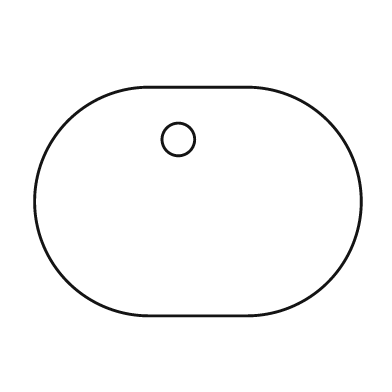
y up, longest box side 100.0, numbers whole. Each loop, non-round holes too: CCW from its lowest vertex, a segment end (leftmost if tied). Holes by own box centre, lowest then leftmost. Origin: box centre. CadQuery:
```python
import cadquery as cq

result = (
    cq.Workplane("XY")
    .moveTo(-15.0, -35.0)
    .lineTo(15.0, -35.0)
    .threePointArc((50.0, 0.0), (15.0, 35.0))
    .lineTo(-15.0, 35.0)
    .threePointArc((-50.0, 0.0), (-15.0, -35.0))
    .close()
    .moveTo(-6.0, 19.0)
    .circle(5.0)
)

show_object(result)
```